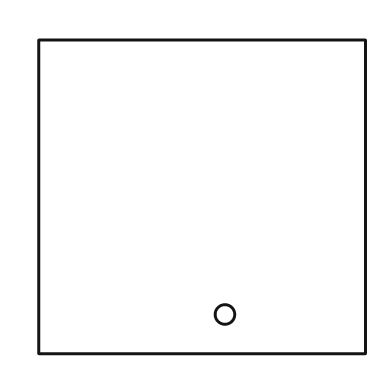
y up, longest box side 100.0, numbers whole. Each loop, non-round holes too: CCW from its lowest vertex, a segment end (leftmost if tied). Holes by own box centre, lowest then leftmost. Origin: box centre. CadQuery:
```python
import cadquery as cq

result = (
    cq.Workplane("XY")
    .moveTo(-50.0, -48.0)
    .lineTo(50.0, -48.0)
    .lineTo(50.0, 48.0)
    .lineTo(-50.0, 48.0)
    .close()
    .moveTo(7.0, -36.0)
    .circle(3.0)
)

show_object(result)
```